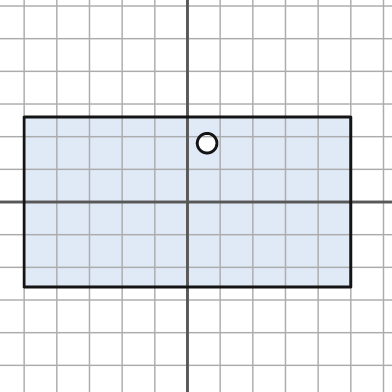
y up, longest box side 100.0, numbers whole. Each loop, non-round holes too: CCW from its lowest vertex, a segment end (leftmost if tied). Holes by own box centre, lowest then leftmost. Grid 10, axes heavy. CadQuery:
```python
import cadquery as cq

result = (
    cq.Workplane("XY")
    .moveTo(-50.0, -26.0)
    .lineTo(50.0, -26.0)
    .lineTo(50.0, 26.0)
    .lineTo(-50.0, 26.0)
    .close()
    .moveTo(6.0, 18.0)
    .circle(3.0)
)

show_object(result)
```